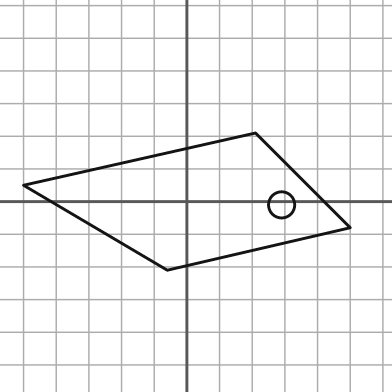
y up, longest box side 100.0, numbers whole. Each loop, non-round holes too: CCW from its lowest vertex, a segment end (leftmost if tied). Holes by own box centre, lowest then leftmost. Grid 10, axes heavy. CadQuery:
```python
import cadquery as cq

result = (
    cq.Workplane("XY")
    .moveTo(-6.0, -21.0)
    .lineTo(50.0, -8.0)
    .lineTo(21.0, 21.0)
    .lineTo(-50.0, 5.0)
    .close()
    .moveTo(29.0, -1.0)
    .circle(4.0)
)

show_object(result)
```